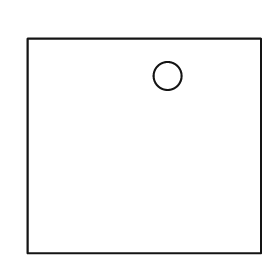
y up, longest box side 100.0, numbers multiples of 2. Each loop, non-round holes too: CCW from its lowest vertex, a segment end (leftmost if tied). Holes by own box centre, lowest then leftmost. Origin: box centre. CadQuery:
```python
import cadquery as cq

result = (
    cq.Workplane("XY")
    .moveTo(-50.0, -46.0)
    .lineTo(50.0, -46.0)
    .lineTo(50.0, 46.0)
    .lineTo(-50.0, 46.0)
    .close()
    .moveTo(10.0, 30.0)
    .circle(6.0)
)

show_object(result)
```